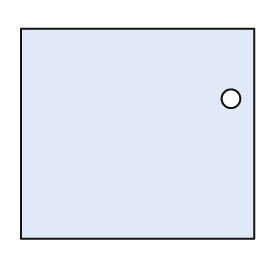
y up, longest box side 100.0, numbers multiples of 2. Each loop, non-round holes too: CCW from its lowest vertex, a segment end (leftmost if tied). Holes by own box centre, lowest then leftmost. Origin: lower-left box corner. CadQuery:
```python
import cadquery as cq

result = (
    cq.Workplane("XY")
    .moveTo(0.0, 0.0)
    .lineTo(100.0, 0.0)
    .lineTo(100.0, 90.0)
    .lineTo(0.0, 90.0)
    .close()
    .moveTo(90.0, 60.0)
    .circle(4.0)
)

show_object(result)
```